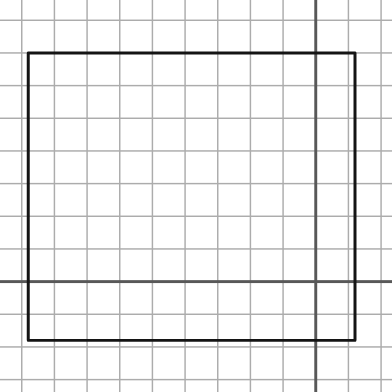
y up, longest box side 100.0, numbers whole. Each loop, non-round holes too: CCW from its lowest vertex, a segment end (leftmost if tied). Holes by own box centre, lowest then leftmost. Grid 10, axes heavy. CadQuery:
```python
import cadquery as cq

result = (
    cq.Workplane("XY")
    .moveTo(-88.0, -18.0)
    .lineTo(12.0, -18.0)
    .lineTo(12.0, 70.0)
    .lineTo(-88.0, 70.0)
    .close()
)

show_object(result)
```